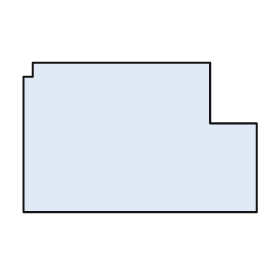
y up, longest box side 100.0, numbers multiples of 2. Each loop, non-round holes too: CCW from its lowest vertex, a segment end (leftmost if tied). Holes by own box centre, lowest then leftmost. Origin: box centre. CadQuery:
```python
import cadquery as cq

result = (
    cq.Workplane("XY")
    .moveTo(-50.0, -32.0)
    .lineTo(50.0, -32.0)
    .lineTo(50.0, 6.0)
    .lineTo(30.0, 6.0)
    .lineTo(30.0, 32.0)
    .lineTo(-46.0, 32.0)
    .lineTo(-46.0, 26.0)
    .lineTo(-50.0, 26.0)
    .close()
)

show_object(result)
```